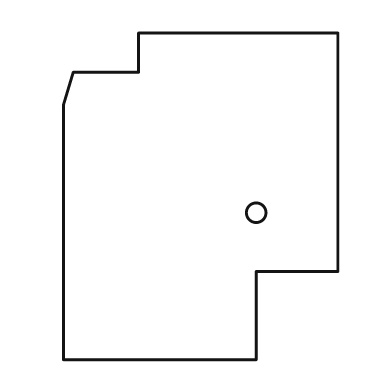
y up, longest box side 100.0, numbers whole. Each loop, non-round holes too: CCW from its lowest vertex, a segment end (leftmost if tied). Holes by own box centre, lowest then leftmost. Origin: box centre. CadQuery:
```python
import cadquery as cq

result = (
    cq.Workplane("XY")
    .moveTo(-42.0, -50.0)
    .lineTo(17.0, -50.0)
    .lineTo(17.0, -23.0)
    .lineTo(42.0, -23.0)
    .lineTo(42.0, 50.0)
    .lineTo(-19.0, 50.0)
    .lineTo(-19.0, 38.0)
    .lineTo(-39.0, 38.0)
    .lineTo(-42.0, 28.0)
    .close()
    .moveTo(17.0, -5.0)
    .circle(3.0)
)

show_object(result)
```